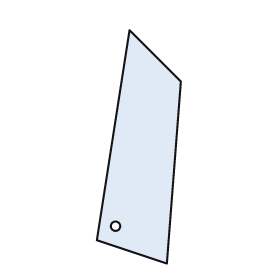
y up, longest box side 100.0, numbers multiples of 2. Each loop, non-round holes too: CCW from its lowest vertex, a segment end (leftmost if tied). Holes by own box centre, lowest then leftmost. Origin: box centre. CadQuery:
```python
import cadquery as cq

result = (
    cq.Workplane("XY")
    .moveTo(12.0, -50.0)
    .lineTo(18.0, 28.0)
    .lineTo(-4.0, 50.0)
    .lineTo(-18.0, -40.0)
    .close()
    .moveTo(-10.0, -34.0)
    .circle(2.0)
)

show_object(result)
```